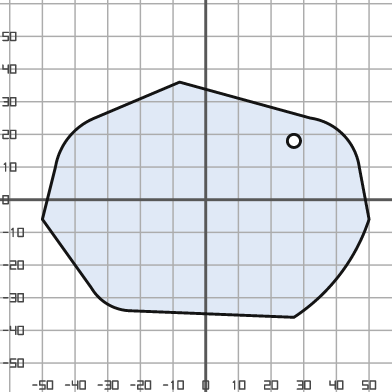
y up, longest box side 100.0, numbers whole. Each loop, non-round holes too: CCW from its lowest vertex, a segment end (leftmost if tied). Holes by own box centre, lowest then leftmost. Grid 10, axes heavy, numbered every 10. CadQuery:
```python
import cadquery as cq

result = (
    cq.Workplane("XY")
    .moveTo(27.0, -36.0)
    .threePointArc((41.0, -23.0), (50.0, -6.0))
    .lineTo(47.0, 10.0)
    .threePointArc((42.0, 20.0), (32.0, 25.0))
    .lineTo(-8.0, 36.0)
    .lineTo(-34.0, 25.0)
    .threePointArc((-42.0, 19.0), (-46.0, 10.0))
    .lineTo(-50.0, -6.0)
    .lineTo(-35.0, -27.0)
    .threePointArc((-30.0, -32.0), (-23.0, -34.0))
    .close()
    .moveTo(27.0, 18.0)
    .circle(2.0)
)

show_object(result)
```